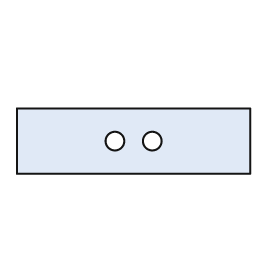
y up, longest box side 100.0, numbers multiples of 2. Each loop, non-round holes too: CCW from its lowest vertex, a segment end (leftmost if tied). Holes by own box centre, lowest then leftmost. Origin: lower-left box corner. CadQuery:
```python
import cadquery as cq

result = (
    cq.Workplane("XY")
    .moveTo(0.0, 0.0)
    .lineTo(100.0, 0.0)
    .lineTo(100.0, 28.0)
    .lineTo(0.0, 28.0)
    .close()
    .moveTo(42.0, 14.0)
    .circle(4.0)
    .moveTo(58.0, 14.0)
    .circle(4.0)
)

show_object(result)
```